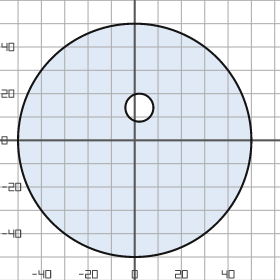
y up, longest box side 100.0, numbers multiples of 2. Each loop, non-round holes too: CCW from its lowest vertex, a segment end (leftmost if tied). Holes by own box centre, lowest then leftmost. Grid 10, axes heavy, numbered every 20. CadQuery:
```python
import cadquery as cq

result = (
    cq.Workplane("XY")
    .moveTo(0.0, 0.0)
    .circle(50.0)
    .moveTo(2.0, 14.0)
    .circle(6.0)
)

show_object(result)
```